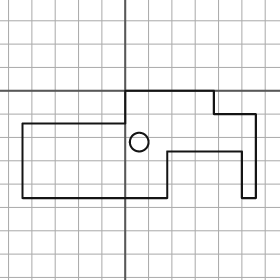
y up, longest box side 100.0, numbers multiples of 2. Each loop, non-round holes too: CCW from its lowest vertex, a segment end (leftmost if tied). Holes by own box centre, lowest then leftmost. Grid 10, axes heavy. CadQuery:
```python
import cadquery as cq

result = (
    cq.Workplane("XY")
    .moveTo(-44.0, -46.0)
    .lineTo(18.0, -46.0)
    .lineTo(18.0, -26.0)
    .lineTo(50.0, -26.0)
    .lineTo(50.0, -46.0)
    .lineTo(56.0, -46.0)
    .lineTo(56.0, -10.0)
    .lineTo(38.0, -10.0)
    .lineTo(38.0, 0.0)
    .lineTo(0.0, 0.0)
    .lineTo(0.0, -14.0)
    .lineTo(-44.0, -14.0)
    .close()
    .moveTo(6.0, -22.0)
    .circle(4.0)
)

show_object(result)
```